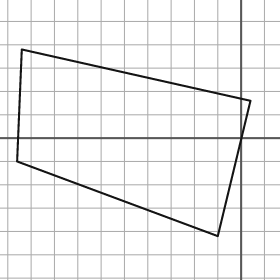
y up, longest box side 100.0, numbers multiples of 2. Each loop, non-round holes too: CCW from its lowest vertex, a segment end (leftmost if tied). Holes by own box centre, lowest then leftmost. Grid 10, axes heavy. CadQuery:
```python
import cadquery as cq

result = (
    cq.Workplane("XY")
    .moveTo(-10.0, -42.0)
    .lineTo(4.0, 16.0)
    .lineTo(-94.0, 38.0)
    .lineTo(-96.0, -10.0)
    .close()
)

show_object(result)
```